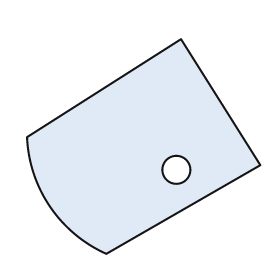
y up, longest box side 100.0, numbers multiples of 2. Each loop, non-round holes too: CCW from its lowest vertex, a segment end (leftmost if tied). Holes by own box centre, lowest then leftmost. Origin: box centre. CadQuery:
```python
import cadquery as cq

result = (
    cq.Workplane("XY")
    .moveTo(-16.0, -46.0)
    .lineTo(50.0, -8.0)
    .lineTo(16.0, 46.0)
    .lineTo(-50.0, 4.0)
    .threePointArc((-40.0, -26.0), (-16.0, -46.0))
    .close()
    .moveTo(14.0, -10.0)
    .circle(6.0)
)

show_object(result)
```